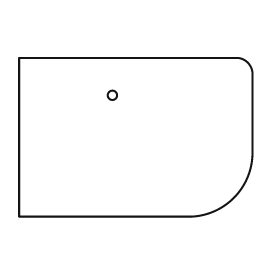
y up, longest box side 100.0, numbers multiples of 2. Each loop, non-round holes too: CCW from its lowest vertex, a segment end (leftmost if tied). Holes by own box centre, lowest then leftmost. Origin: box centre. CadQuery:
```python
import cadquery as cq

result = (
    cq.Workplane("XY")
    .moveTo(-50.0, -34.0)
    .lineTo(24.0, -34.0)
    .threePointArc((42.0, -26.0), (50.0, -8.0))
    .lineTo(50.0, 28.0)
    .threePointArc((48.0, 32.0), (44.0, 34.0))
    .lineTo(-50.0, 34.0)
    .close()
    .moveTo(-10.0, 18.0)
    .circle(2.0)
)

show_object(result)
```